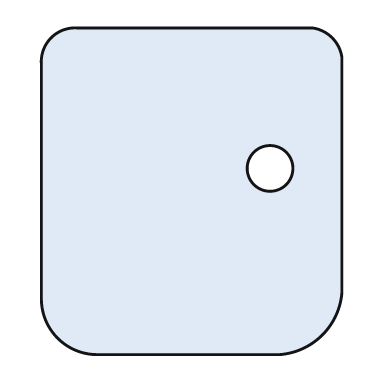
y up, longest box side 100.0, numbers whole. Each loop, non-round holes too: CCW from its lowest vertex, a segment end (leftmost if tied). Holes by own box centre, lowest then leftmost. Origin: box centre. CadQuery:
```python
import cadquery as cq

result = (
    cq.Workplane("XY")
    .moveTo(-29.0, -50.0)
    .lineTo(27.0, -50.0)
    .threePointArc((40.0, -44.0), (46.0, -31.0))
    .lineTo(46.0, 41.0)
    .threePointArc((43.0, 47.0), (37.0, 50.0))
    .lineTo(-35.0, 50.0)
    .threePointArc((-43.0, 47.0), (-46.0, 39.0))
    .lineTo(-46.0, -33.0)
    .threePointArc((-41.0, -45.0), (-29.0, -50.0))
    .close()
    .moveTo(24.0, 7.0)
    .circle(7.0)
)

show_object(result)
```